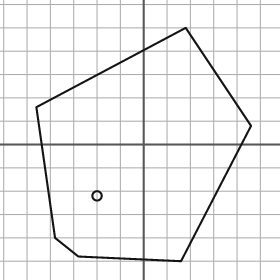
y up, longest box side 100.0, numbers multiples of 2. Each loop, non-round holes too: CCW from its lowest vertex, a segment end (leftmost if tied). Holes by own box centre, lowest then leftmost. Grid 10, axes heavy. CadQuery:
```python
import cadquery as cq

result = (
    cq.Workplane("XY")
    .moveTo(16.0, -50.0)
    .lineTo(46.0, 8.0)
    .lineTo(18.0, 50.0)
    .lineTo(-46.0, 16.0)
    .lineTo(-38.0, -40.0)
    .lineTo(-28.0, -48.0)
    .close()
    .moveTo(-20.0, -22.0)
    .circle(2.0)
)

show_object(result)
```